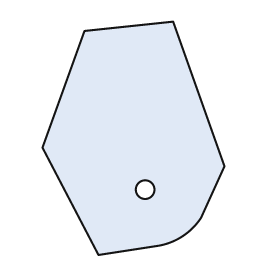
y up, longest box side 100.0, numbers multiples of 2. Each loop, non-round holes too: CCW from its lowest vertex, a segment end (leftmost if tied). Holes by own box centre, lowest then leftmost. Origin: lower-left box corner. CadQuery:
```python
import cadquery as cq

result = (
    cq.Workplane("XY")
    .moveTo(24.0, 0.0)
    .lineTo(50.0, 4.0)
    .threePointArc((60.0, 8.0), (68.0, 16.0))
    .lineTo(78.0, 38.0)
    .lineTo(56.0, 100.0)
    .lineTo(18.0, 96.0)
    .lineTo(0.0, 46.0)
    .close()
    .moveTo(44.0, 28.0)
    .circle(4.0)
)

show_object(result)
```